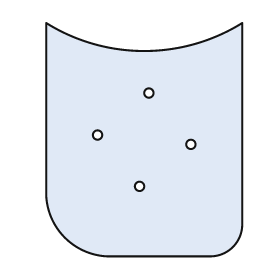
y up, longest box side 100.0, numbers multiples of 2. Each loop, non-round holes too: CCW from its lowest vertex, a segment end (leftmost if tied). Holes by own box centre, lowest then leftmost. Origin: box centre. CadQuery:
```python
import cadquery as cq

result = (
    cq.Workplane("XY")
    .moveTo(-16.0, -50.0)
    .lineTo(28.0, -50.0)
    .threePointArc((38.0, -46.0), (42.0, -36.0))
    .lineTo(42.0, 50.0)
    .threePointArc((0.0, 38.0), (-42.0, 50.0))
    .lineTo(-42.0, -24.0)
    .threePointArc((-34.0, -42.0), (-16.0, -50.0))
    .close()
    .moveTo(-2.0, -20.0)
    .circle(2.0)
    .moveTo(20.0, -2.0)
    .circle(2.0)
    .moveTo(-20.0, 2.0)
    .circle(2.0)
    .moveTo(2.0, 20.0)
    .circle(2.0)
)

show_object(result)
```